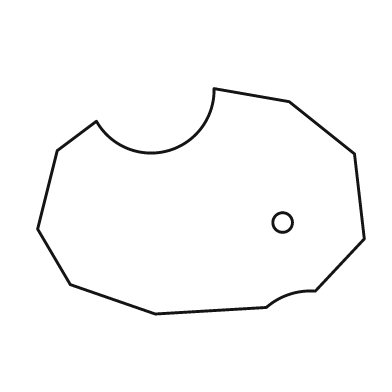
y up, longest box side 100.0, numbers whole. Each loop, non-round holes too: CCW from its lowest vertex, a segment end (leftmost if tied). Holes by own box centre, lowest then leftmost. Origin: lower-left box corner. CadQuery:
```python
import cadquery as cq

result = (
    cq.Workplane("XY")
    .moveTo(36.0, 0.0)
    .lineTo(70.0, 2.0)
    .threePointArc((77.0, 6.0), (85.0, 7.0))
    .lineTo(100.0, 23.0)
    .lineTo(97.0, 49.0)
    .lineTo(77.0, 65.0)
    .lineTo(54.0, 69.0)
    .threePointArc((40.0, 50.0), (18.0, 59.0))
    .lineTo(6.0, 50.0)
    .lineTo(0.0, 26.0)
    .lineTo(10.0, 9.0)
    .close()
    .moveTo(75.0, 28.0)
    .circle(3.0)
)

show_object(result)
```